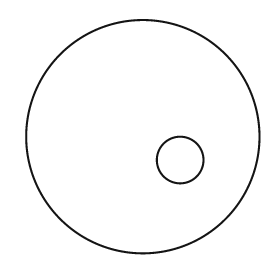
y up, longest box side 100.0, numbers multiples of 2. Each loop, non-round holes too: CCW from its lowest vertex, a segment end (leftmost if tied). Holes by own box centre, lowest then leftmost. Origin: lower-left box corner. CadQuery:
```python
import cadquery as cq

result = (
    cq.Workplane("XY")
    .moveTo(50.0, 50.0)
    .circle(50.0)
    .moveTo(66.0, 40.0)
    .circle(10.0)
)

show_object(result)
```